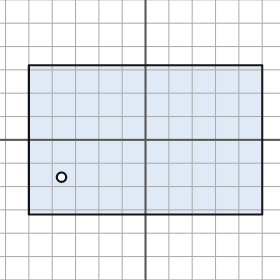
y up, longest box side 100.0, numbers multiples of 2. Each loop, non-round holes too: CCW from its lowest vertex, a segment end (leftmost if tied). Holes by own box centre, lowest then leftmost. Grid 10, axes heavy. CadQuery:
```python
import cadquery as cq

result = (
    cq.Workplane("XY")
    .moveTo(-50.0, -32.0)
    .lineTo(50.0, -32.0)
    .lineTo(50.0, 32.0)
    .lineTo(-50.0, 32.0)
    .close()
    .moveTo(-36.0, -16.0)
    .circle(2.0)
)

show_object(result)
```